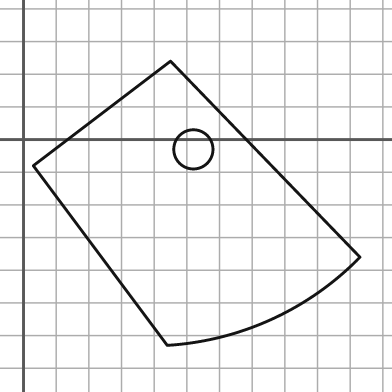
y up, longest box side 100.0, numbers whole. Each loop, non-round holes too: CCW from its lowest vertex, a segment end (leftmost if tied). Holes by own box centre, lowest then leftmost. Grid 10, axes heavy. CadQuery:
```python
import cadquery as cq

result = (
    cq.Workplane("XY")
    .moveTo(44.0, -63.0)
    .threePointArc((76.0, -55.0), (103.0, -36.0))
    .lineTo(45.0, 24.0)
    .lineTo(3.0, -8.0)
    .close()
    .moveTo(52.0, -3.0)
    .circle(6.0)
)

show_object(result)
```